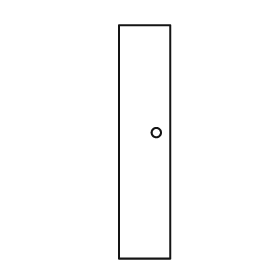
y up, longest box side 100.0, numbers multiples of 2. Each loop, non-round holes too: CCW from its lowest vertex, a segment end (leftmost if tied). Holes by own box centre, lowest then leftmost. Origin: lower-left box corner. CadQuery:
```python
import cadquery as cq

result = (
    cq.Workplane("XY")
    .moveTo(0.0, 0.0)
    .lineTo(22.0, 0.0)
    .lineTo(22.0, 100.0)
    .lineTo(0.0, 100.0)
    .close()
    .moveTo(16.0, 54.0)
    .circle(2.0)
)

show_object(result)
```